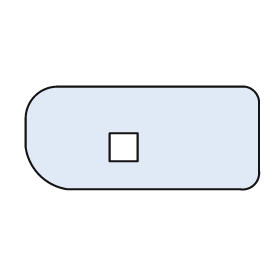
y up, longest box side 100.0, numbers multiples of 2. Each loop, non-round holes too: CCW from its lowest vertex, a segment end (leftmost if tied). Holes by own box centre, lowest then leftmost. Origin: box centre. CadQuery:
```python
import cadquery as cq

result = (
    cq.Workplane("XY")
    .moveTo(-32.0, -22.0)
    .lineTo(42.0, -22.0)
    .threePointArc((48.0, -20.0), (50.0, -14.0))
    .lineTo(50.0, 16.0)
    .threePointArc((48.0, 20.0), (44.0, 22.0))
    .lineTo(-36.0, 22.0)
    .threePointArc((-46.0, 18.0), (-50.0, 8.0))
    .lineTo(-50.0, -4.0)
    .threePointArc((-44.0, -16.0), (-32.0, -22.0))
    .close()
    .moveTo(-14.0, -10.0)
    .lineTo(-2.0, -10.0)
    .lineTo(-2.0, 2.0)
    .lineTo(-14.0, 2.0)
    .close()
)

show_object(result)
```